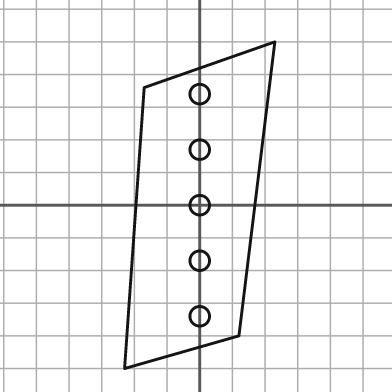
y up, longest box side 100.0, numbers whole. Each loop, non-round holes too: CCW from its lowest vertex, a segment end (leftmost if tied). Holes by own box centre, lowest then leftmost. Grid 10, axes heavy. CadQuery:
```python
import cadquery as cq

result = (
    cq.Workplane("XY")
    .moveTo(-23.0, -50.0)
    .lineTo(12.0, -40.0)
    .lineTo(23.0, 50.0)
    .lineTo(-17.0, 36.0)
    .close()
    .moveTo(0.0, -34.0)
    .circle(3.0)
    .moveTo(0.0, -17.0)
    .circle(3.0)
    .moveTo(0.0, 0.0)
    .circle(3.0)
    .moveTo(0.0, 17.0)
    .circle(3.0)
    .moveTo(0.0, 34.0)
    .circle(3.0)
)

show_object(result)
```